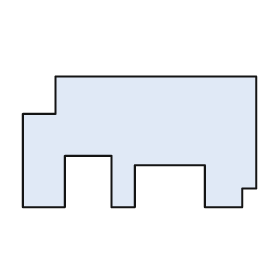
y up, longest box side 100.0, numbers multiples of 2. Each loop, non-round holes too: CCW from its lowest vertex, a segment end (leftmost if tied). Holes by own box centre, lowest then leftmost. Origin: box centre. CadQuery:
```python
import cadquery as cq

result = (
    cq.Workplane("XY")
    .moveTo(-50.0, -28.0)
    .lineTo(-32.0, -28.0)
    .lineTo(-32.0, -6.0)
    .lineTo(-12.0, -6.0)
    .lineTo(-12.0, -28.0)
    .lineTo(-2.0, -28.0)
    .lineTo(-2.0, -10.0)
    .lineTo(28.0, -10.0)
    .lineTo(28.0, -28.0)
    .lineTo(44.0, -28.0)
    .lineTo(44.0, -20.0)
    .lineTo(50.0, -20.0)
    .lineTo(50.0, 28.0)
    .lineTo(-36.0, 28.0)
    .lineTo(-36.0, 12.0)
    .lineTo(-50.0, 12.0)
    .close()
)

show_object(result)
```